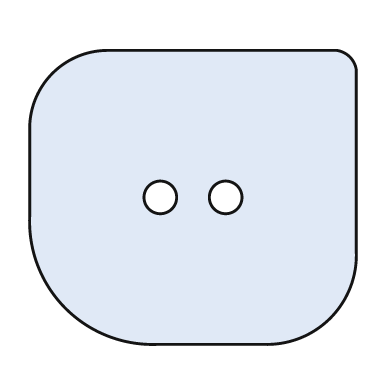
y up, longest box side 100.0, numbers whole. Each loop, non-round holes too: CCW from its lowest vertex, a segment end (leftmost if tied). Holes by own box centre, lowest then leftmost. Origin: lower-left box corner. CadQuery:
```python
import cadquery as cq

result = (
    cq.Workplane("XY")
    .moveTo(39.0, 0.0)
    .lineTo(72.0, 0.0)
    .threePointArc((92.0, 8.0), (100.0, 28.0))
    .lineTo(100.0, 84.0)
    .threePointArc((98.0, 88.0), (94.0, 90.0))
    .lineTo(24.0, 90.0)
    .threePointArc((7.0, 83.0), (0.0, 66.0))
    .lineTo(0.0, 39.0)
    .threePointArc((11.0, 11.0), (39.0, 0.0))
    .close()
    .moveTo(40.0, 45.0)
    .circle(5.0)
    .moveTo(60.0, 45.0)
    .circle(5.0)
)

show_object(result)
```